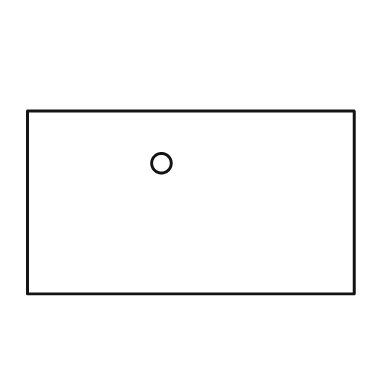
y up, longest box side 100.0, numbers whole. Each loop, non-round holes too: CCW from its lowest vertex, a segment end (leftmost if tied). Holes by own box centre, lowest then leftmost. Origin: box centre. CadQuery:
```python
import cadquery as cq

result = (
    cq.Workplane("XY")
    .moveTo(-50.0, -28.0)
    .lineTo(50.0, -28.0)
    .lineTo(50.0, 28.0)
    .lineTo(-50.0, 28.0)
    .close()
    .moveTo(-9.0, 12.0)
    .circle(3.0)
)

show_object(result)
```